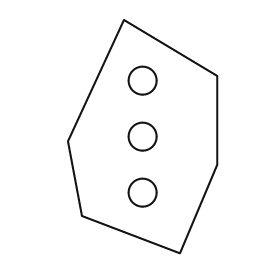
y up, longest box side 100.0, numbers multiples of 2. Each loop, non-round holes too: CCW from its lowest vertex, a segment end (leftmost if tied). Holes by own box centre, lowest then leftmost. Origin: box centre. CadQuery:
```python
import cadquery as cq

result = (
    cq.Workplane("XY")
    .moveTo(16.0, -50.0)
    .lineTo(32.0, -12.0)
    .lineTo(32.0, 26.0)
    .lineTo(-8.0, 50.0)
    .lineTo(-32.0, -2.0)
    .lineTo(-26.0, -34.0)
    .close()
    .moveTo(0.0, -24.0)
    .circle(6.0)
    .moveTo(0.0, 0.0)
    .circle(6.0)
    .moveTo(0.0, 24.0)
    .circle(6.0)
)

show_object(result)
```